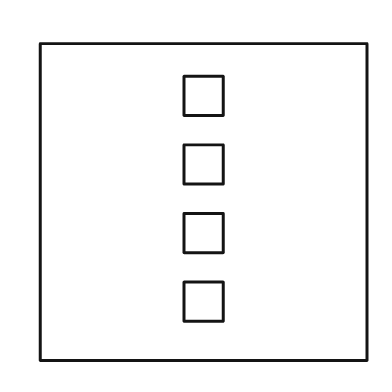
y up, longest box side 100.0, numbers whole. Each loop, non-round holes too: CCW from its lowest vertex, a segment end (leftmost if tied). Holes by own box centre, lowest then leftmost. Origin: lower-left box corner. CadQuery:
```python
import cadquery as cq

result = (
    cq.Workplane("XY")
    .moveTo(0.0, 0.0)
    .lineTo(100.0, 0.0)
    .lineTo(100.0, 97.0)
    .lineTo(0.0, 97.0)
    .close()
    .moveTo(44.0, 12.0)
    .lineTo(56.0, 12.0)
    .lineTo(56.0, 24.0)
    .lineTo(44.0, 24.0)
    .close()
    .moveTo(44.0, 33.0)
    .lineTo(56.0, 33.0)
    .lineTo(56.0, 45.0)
    .lineTo(44.0, 45.0)
    .close()
    .moveTo(44.0, 54.0)
    .lineTo(56.0, 54.0)
    .lineTo(56.0, 66.0)
    .lineTo(44.0, 66.0)
    .close()
    .moveTo(44.0, 75.0)
    .lineTo(56.0, 75.0)
    .lineTo(56.0, 87.0)
    .lineTo(44.0, 87.0)
    .close()
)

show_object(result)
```